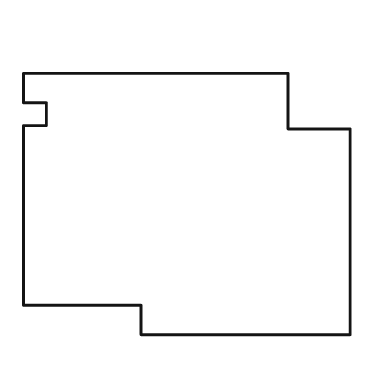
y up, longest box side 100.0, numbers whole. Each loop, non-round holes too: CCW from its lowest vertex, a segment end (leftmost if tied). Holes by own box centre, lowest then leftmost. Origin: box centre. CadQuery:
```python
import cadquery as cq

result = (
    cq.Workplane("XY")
    .moveTo(-14.0, -40.0)
    .lineTo(50.0, -40.0)
    .lineTo(50.0, 23.0)
    .lineTo(31.0, 23.0)
    .lineTo(31.0, 40.0)
    .lineTo(-50.0, 40.0)
    .lineTo(-50.0, 31.0)
    .lineTo(-43.0, 31.0)
    .lineTo(-43.0, 24.0)
    .lineTo(-50.0, 24.0)
    .lineTo(-50.0, -31.0)
    .lineTo(-14.0, -31.0)
    .close()
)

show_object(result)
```